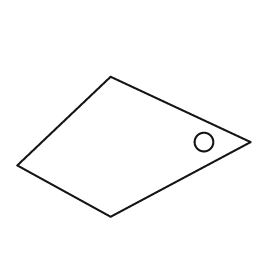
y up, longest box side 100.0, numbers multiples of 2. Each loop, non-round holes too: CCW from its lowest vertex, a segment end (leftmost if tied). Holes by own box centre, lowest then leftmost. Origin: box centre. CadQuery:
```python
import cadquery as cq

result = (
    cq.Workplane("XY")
    .moveTo(-10.0, -30.0)
    .lineTo(50.0, 2.0)
    .lineTo(-10.0, 30.0)
    .lineTo(-50.0, -8.0)
    .close()
    .moveTo(30.0, 2.0)
    .circle(4.0)
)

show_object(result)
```